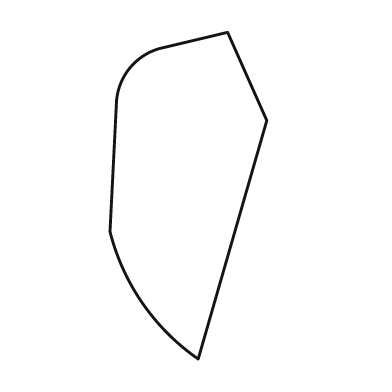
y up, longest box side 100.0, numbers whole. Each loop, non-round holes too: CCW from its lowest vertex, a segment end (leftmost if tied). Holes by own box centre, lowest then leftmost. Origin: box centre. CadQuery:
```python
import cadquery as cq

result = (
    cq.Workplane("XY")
    .moveTo(3.0, -50.0)
    .lineTo(24.0, 23.0)
    .lineTo(12.0, 50.0)
    .lineTo(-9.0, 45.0)
    .threePointArc((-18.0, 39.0), (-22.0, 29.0))
    .lineTo(-24.0, -11.0)
    .threePointArc((-14.0, -33.0), (3.0, -50.0))
    .close()
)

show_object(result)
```